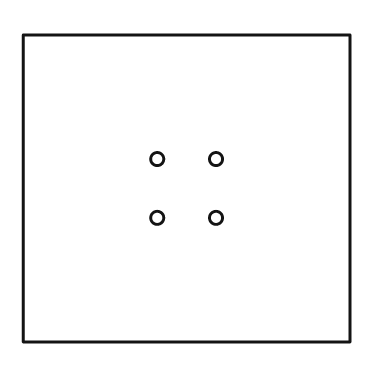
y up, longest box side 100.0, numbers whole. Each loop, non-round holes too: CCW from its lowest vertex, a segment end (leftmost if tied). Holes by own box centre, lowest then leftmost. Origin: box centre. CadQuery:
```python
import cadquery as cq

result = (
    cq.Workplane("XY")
    .moveTo(-50.0, -47.0)
    .lineTo(50.0, -47.0)
    .lineTo(50.0, 47.0)
    .lineTo(-50.0, 47.0)
    .close()
    .moveTo(-9.0, -9.0)
    .circle(2.0)
    .moveTo(9.0, -9.0)
    .circle(2.0)
    .moveTo(-9.0, 9.0)
    .circle(2.0)
    .moveTo(9.0, 9.0)
    .circle(2.0)
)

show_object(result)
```